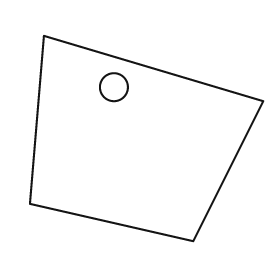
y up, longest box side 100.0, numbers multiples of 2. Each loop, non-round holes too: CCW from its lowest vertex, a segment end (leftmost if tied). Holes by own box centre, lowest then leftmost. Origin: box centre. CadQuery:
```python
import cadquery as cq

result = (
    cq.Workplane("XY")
    .moveTo(20.0, -44.0)
    .lineTo(50.0, 16.0)
    .lineTo(-44.0, 44.0)
    .lineTo(-50.0, -28.0)
    .close()
    .moveTo(-14.0, 22.0)
    .circle(6.0)
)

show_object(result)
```